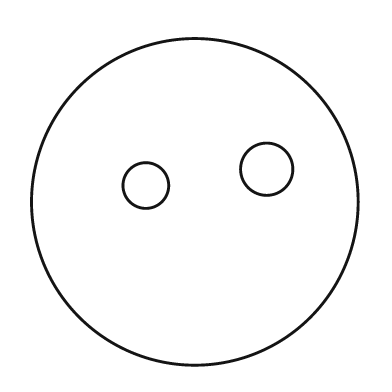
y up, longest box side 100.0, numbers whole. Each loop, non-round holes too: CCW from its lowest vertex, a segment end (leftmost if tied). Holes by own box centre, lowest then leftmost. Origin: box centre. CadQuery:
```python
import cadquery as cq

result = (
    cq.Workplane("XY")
    .moveTo(0.0, 0.0)
    .circle(50.0)
    .moveTo(-15.0, 5.0)
    .circle(7.0)
    .moveTo(22.0, 10.0)
    .circle(8.0)
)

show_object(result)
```